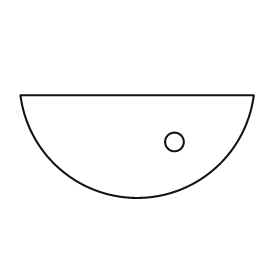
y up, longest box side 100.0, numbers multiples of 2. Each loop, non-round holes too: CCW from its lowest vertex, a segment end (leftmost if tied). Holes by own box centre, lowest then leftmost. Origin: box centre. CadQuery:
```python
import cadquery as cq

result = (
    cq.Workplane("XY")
    .moveTo(-50.0, 22.0)
    .threePointArc((0.0, -22.0), (50.0, 22.0))
    .close()
    .moveTo(16.0, 2.0)
    .circle(4.0)
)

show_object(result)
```